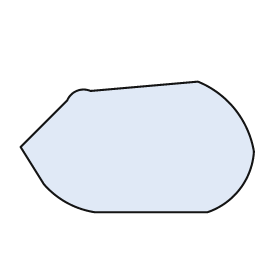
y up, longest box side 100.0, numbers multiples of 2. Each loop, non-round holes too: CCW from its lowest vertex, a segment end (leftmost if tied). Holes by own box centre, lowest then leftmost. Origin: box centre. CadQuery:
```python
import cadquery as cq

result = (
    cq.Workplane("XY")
    .moveTo(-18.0, -28.0)
    .lineTo(30.0, -28.0)
    .threePointArc((44.0, -18.0), (50.0, -2.0))
    .threePointArc((42.0, 16.0), (26.0, 28.0))
    .lineTo(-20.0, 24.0)
    .threePointArc((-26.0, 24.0), (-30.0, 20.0))
    .lineTo(-50.0, 0.0)
    .lineTo(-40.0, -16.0)
    .threePointArc((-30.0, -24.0), (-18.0, -28.0))
    .close()
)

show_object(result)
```